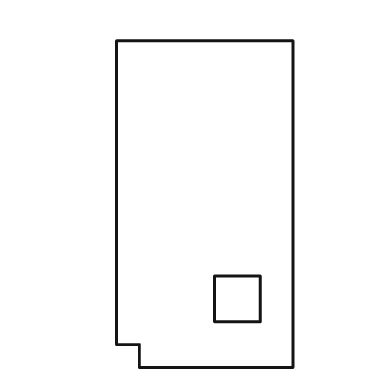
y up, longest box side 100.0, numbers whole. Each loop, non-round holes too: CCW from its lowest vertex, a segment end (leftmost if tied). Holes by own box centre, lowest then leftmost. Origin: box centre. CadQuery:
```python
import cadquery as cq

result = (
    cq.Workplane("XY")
    .moveTo(-20.0, -50.0)
    .lineTo(27.0, -50.0)
    .lineTo(27.0, 50.0)
    .lineTo(-27.0, 50.0)
    .lineTo(-27.0, -43.0)
    .lineTo(-20.0, -43.0)
    .close()
    .moveTo(3.0, -36.0)
    .lineTo(17.0, -36.0)
    .lineTo(17.0, -22.0)
    .lineTo(3.0, -22.0)
    .close()
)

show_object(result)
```